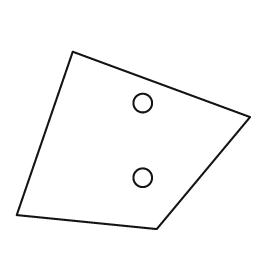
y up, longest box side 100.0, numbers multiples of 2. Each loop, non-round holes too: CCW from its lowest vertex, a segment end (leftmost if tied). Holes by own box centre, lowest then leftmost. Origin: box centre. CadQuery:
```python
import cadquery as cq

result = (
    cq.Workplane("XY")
    .moveTo(10.0, -38.0)
    .lineTo(50.0, 10.0)
    .lineTo(-26.0, 38.0)
    .lineTo(-50.0, -32.0)
    .close()
    .moveTo(4.0, -16.0)
    .circle(4.0)
    .moveTo(4.0, 16.0)
    .circle(4.0)
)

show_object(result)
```